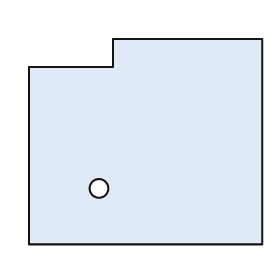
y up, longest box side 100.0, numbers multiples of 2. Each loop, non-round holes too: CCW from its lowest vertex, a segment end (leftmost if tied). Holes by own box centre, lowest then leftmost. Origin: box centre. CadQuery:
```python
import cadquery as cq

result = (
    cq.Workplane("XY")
    .moveTo(-50.0, -44.0)
    .lineTo(50.0, -44.0)
    .lineTo(50.0, 44.0)
    .lineTo(-14.0, 44.0)
    .lineTo(-14.0, 32.0)
    .lineTo(-50.0, 32.0)
    .close()
    .moveTo(-20.0, -20.0)
    .circle(4.0)
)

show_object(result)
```